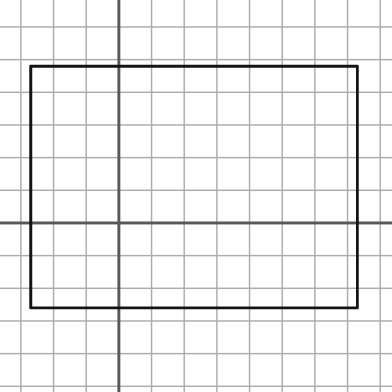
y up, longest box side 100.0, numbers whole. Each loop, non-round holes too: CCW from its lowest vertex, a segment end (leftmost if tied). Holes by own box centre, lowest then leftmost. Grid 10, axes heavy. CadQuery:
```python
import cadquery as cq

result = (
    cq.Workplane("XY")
    .moveTo(-27.0, -26.0)
    .lineTo(73.0, -26.0)
    .lineTo(73.0, 48.0)
    .lineTo(-27.0, 48.0)
    .close()
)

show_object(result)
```